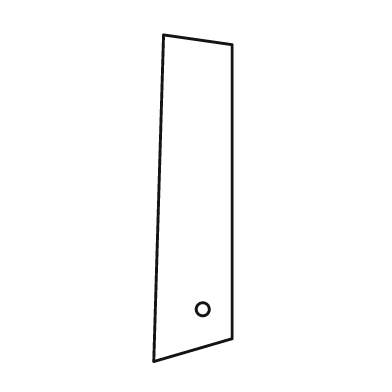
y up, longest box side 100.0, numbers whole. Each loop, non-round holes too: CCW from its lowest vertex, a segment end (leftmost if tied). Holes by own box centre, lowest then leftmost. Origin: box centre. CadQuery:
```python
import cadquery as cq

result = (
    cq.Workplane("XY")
    .moveTo(-12.0, -50.0)
    .lineTo(12.0, -43.0)
    .lineTo(12.0, 47.0)
    .lineTo(-9.0, 50.0)
    .close()
    .moveTo(3.0, -34.0)
    .circle(2.0)
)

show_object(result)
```